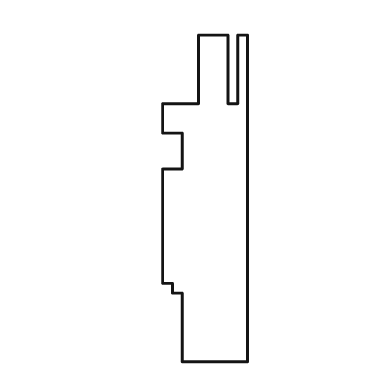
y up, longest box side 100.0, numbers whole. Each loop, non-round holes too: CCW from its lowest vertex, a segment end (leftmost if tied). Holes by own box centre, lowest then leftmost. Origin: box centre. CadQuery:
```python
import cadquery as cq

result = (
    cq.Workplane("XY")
    .moveTo(-7.0, -50.0)
    .lineTo(13.0, -50.0)
    .lineTo(13.0, 50.0)
    .lineTo(10.0, 50.0)
    .lineTo(10.0, 29.0)
    .lineTo(7.0, 29.0)
    .lineTo(7.0, 50.0)
    .lineTo(-2.0, 50.0)
    .lineTo(-2.0, 29.0)
    .lineTo(-13.0, 29.0)
    .lineTo(-13.0, 20.0)
    .lineTo(-7.0, 20.0)
    .lineTo(-7.0, 9.0)
    .lineTo(-13.0, 9.0)
    .lineTo(-13.0, -26.0)
    .lineTo(-10.0, -26.0)
    .lineTo(-10.0, -29.0)
    .lineTo(-7.0, -29.0)
    .close()
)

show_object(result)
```